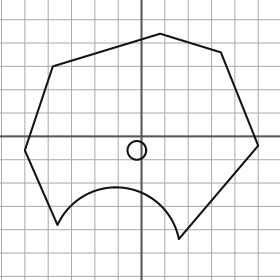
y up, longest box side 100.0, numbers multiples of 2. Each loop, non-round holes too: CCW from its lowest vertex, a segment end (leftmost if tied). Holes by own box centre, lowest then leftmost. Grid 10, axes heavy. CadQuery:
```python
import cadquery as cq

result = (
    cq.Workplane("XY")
    .moveTo(16.0, -44.0)
    .lineTo(50.0, -4.0)
    .lineTo(34.0, 36.0)
    .lineTo(8.0, 44.0)
    .lineTo(-38.0, 30.0)
    .lineTo(-50.0, -6.0)
    .lineTo(-36.0, -38.0)
    .threePointArc((-8.0, -22.0), (16.0, -44.0))
    .close()
    .moveTo(-2.0, -6.0)
    .circle(4.0)
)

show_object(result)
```